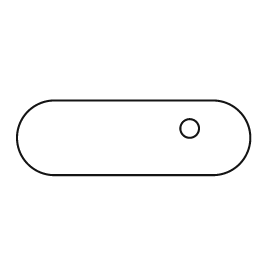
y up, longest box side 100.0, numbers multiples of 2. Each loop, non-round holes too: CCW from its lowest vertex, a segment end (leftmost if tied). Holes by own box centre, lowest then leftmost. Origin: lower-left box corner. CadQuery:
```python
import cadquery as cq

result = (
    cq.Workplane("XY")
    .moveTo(16.0, 0.0)
    .lineTo(84.0, 0.0)
    .threePointArc((100.0, 16.0), (84.0, 32.0))
    .lineTo(16.0, 32.0)
    .threePointArc((0.0, 16.0), (16.0, 0.0))
    .close()
    .moveTo(74.0, 20.0)
    .circle(4.0)
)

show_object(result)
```